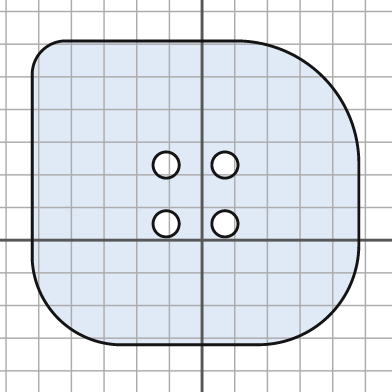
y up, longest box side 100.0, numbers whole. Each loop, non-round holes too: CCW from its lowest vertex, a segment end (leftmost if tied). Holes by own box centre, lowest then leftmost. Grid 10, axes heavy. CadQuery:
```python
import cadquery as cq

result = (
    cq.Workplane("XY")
    .moveTo(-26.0, -32.0)
    .lineTo(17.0, -32.0)
    .threePointArc((39.0, -23.0), (48.0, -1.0))
    .lineTo(48.0, 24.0)
    .threePointArc((37.0, 50.0), (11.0, 61.0))
    .lineTo(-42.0, 61.0)
    .threePointArc((-49.0, 58.0), (-52.0, 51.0))
    .lineTo(-52.0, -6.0)
    .threePointArc((-44.0, -24.0), (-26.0, -32.0))
    .close()
    .moveTo(-11.0, 5.0)
    .circle(4.0)
    .moveTo(7.0, 5.0)
    .circle(4.0)
    .moveTo(-11.0, 23.0)
    .circle(4.0)
    .moveTo(7.0, 23.0)
    .circle(4.0)
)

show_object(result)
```